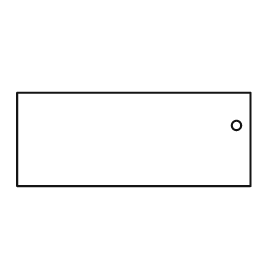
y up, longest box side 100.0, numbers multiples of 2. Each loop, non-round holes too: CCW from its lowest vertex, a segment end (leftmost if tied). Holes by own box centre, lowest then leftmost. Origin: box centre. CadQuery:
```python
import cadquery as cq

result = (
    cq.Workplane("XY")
    .moveTo(-50.0, -20.0)
    .lineTo(50.0, -20.0)
    .lineTo(50.0, 20.0)
    .lineTo(-50.0, 20.0)
    .close()
    .moveTo(44.0, 6.0)
    .circle(2.0)
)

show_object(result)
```